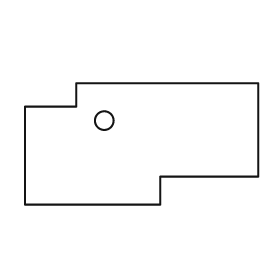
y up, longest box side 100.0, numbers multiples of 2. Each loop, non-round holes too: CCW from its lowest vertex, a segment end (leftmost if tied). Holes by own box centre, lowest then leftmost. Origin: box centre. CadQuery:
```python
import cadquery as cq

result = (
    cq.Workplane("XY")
    .moveTo(-50.0, -26.0)
    .lineTo(8.0, -26.0)
    .lineTo(8.0, -14.0)
    .lineTo(50.0, -14.0)
    .lineTo(50.0, 26.0)
    .lineTo(-28.0, 26.0)
    .lineTo(-28.0, 16.0)
    .lineTo(-50.0, 16.0)
    .close()
    .moveTo(-16.0, 10.0)
    .circle(4.0)
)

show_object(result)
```